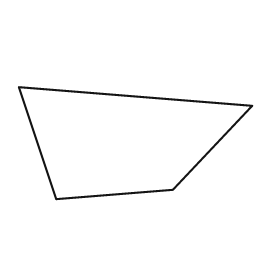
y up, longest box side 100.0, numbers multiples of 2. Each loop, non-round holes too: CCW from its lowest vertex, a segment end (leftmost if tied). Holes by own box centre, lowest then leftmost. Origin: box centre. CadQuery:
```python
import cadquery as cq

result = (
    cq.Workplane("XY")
    .moveTo(-34.0, -24.0)
    .lineTo(16.0, -20.0)
    .lineTo(50.0, 16.0)
    .lineTo(-50.0, 24.0)
    .close()
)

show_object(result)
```